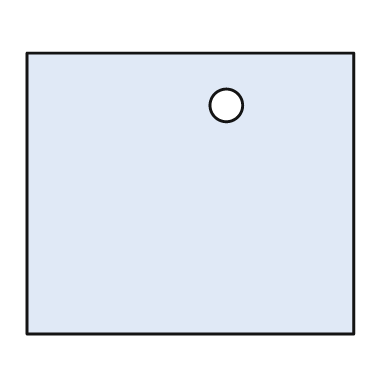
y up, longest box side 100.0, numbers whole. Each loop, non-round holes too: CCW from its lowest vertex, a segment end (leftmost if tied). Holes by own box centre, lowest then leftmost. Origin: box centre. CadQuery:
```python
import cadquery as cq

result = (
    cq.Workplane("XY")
    .moveTo(-50.0, -43.0)
    .lineTo(50.0, -43.0)
    .lineTo(50.0, 43.0)
    .lineTo(-50.0, 43.0)
    .close()
    .moveTo(11.0, 27.0)
    .circle(5.0)
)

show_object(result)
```